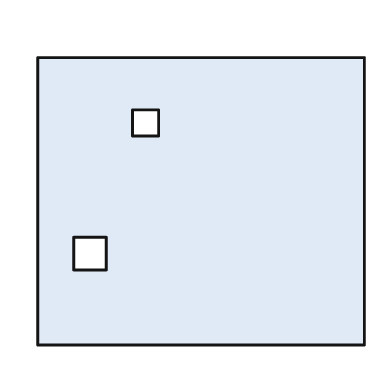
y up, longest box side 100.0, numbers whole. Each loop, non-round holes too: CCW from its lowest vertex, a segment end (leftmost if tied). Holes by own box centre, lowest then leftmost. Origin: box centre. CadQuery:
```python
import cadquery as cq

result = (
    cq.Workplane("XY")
    .moveTo(-50.0, -44.0)
    .lineTo(50.0, -44.0)
    .lineTo(50.0, 44.0)
    .lineTo(-50.0, 44.0)
    .close()
    .moveTo(-39.0, -21.0)
    .lineTo(-29.0, -21.0)
    .lineTo(-29.0, -11.0)
    .lineTo(-39.0, -11.0)
    .close()
    .moveTo(-21.0, 20.0)
    .lineTo(-13.0, 20.0)
    .lineTo(-13.0, 28.0)
    .lineTo(-21.0, 28.0)
    .close()
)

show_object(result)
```